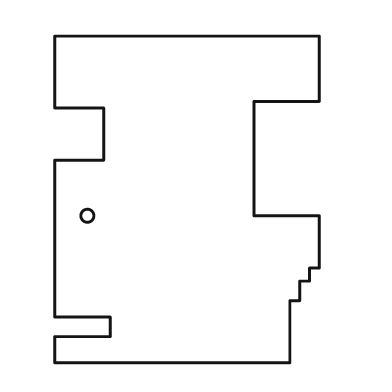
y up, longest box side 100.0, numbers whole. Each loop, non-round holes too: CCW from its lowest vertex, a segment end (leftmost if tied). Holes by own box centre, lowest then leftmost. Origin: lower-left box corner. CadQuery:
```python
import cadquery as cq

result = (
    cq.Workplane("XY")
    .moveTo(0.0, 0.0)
    .lineTo(72.0, 0.0)
    .lineTo(72.0, 19.0)
    .lineTo(75.0, 19.0)
    .lineTo(75.0, 25.0)
    .lineTo(78.0, 25.0)
    .lineTo(78.0, 29.0)
    .lineTo(81.0, 29.0)
    .lineTo(81.0, 45.0)
    .lineTo(61.0, 45.0)
    .lineTo(61.0, 80.0)
    .lineTo(81.0, 80.0)
    .lineTo(81.0, 100.0)
    .lineTo(0.0, 100.0)
    .lineTo(0.0, 78.0)
    .lineTo(15.0, 78.0)
    .lineTo(15.0, 62.0)
    .lineTo(0.0, 62.0)
    .lineTo(0.0, 14.0)
    .lineTo(17.0, 14.0)
    .lineTo(17.0, 8.0)
    .lineTo(0.0, 8.0)
    .close()
    .moveTo(10.0, 45.0)
    .circle(2.0)
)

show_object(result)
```